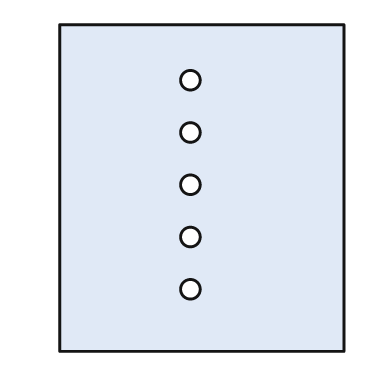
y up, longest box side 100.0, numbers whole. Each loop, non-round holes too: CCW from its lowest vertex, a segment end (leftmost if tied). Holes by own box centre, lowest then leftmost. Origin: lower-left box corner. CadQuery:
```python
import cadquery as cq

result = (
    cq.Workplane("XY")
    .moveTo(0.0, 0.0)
    .lineTo(87.0, 0.0)
    .lineTo(87.0, 100.0)
    .lineTo(0.0, 100.0)
    .close()
    .moveTo(40.0, 19.0)
    .circle(3.0)
    .moveTo(40.0, 35.0)
    .circle(3.0)
    .moveTo(40.0, 51.0)
    .circle(3.0)
    .moveTo(40.0, 67.0)
    .circle(3.0)
    .moveTo(40.0, 83.0)
    .circle(3.0)
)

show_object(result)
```